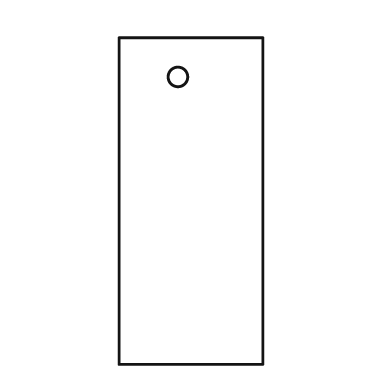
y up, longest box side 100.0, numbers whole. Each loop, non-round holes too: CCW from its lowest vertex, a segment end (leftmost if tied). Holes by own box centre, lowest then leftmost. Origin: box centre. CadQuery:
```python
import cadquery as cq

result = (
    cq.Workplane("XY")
    .moveTo(-22.0, -50.0)
    .lineTo(22.0, -50.0)
    .lineTo(22.0, 50.0)
    .lineTo(-22.0, 50.0)
    .close()
    .moveTo(-4.0, 38.0)
    .circle(3.0)
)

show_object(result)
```